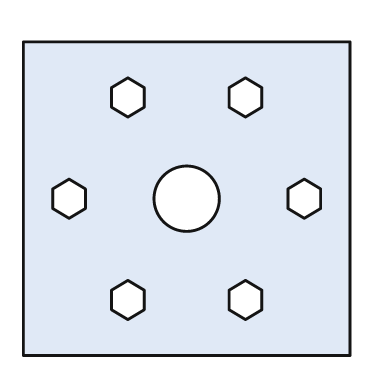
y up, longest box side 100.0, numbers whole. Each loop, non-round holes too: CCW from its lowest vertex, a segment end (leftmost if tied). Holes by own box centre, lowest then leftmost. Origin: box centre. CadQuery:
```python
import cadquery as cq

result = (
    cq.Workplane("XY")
    .moveTo(-50.0, -48.0)
    .lineTo(50.0, -48.0)
    .lineTo(50.0, 48.0)
    .lineTo(-50.0, 48.0)
    .close()
    .moveTo(-18.0, -37.0)
    .lineTo(-13.0, -34.0)
    .lineTo(-13.0, -28.0)
    .lineTo(-18.0, -25.0)
    .lineTo(-23.0, -28.0)
    .lineTo(-23.0, -34.0)
    .close()
    .moveTo(18.0, -37.0)
    .lineTo(23.0, -34.0)
    .lineTo(23.0, -28.0)
    .lineTo(18.0, -25.0)
    .lineTo(13.0, -28.0)
    .lineTo(13.0, -34.0)
    .close()
    .moveTo(-36.0, -6.0)
    .lineTo(-31.0, -3.0)
    .lineTo(-31.0, 3.0)
    .lineTo(-36.0, 6.0)
    .lineTo(-41.0, 3.0)
    .lineTo(-41.0, -3.0)
    .close()
    .moveTo(0.0, 0.0)
    .circle(10.0)
    .moveTo(36.0, -6.0)
    .lineTo(41.0, -3.0)
    .lineTo(41.0, 3.0)
    .lineTo(36.0, 6.0)
    .lineTo(31.0, 3.0)
    .lineTo(31.0, -3.0)
    .close()
    .moveTo(-18.0, 25.0)
    .lineTo(-13.0, 28.0)
    .lineTo(-13.0, 34.0)
    .lineTo(-18.0, 37.0)
    .lineTo(-23.0, 34.0)
    .lineTo(-23.0, 28.0)
    .close()
    .moveTo(18.0, 25.0)
    .lineTo(23.0, 28.0)
    .lineTo(23.0, 34.0)
    .lineTo(18.0, 37.0)
    .lineTo(13.0, 34.0)
    .lineTo(13.0, 28.0)
    .close()
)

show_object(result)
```